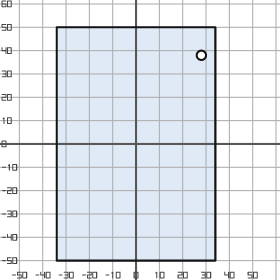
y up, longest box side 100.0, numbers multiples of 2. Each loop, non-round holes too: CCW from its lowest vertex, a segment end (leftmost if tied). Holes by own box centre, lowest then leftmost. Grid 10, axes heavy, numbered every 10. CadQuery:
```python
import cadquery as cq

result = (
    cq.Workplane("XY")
    .moveTo(-34.0, -50.0)
    .lineTo(34.0, -50.0)
    .lineTo(34.0, 50.0)
    .lineTo(-34.0, 50.0)
    .close()
    .moveTo(28.0, 38.0)
    .circle(2.0)
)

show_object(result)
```